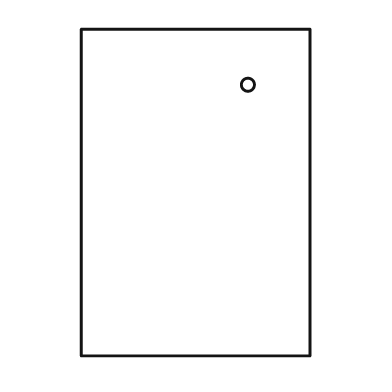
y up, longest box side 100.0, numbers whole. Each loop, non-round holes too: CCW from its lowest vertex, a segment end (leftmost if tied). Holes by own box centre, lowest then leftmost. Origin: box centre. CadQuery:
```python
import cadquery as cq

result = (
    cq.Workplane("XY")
    .moveTo(-35.0, -50.0)
    .lineTo(35.0, -50.0)
    .lineTo(35.0, 50.0)
    .lineTo(-35.0, 50.0)
    .close()
    .moveTo(16.0, 33.0)
    .circle(2.0)
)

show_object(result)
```